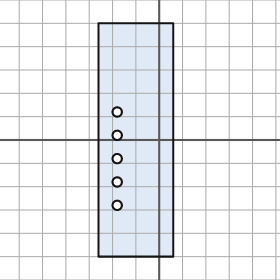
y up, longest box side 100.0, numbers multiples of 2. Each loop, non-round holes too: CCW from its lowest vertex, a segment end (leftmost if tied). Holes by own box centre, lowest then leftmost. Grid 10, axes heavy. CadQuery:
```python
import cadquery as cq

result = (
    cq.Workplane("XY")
    .moveTo(-26.0, -50.0)
    .lineTo(6.0, -50.0)
    .lineTo(6.0, 50.0)
    .lineTo(-26.0, 50.0)
    .close()
    .moveTo(-18.0, -28.0)
    .circle(2.0)
    .moveTo(-18.0, -18.0)
    .circle(2.0)
    .moveTo(-18.0, -8.0)
    .circle(2.0)
    .moveTo(-18.0, 2.0)
    .circle(2.0)
    .moveTo(-18.0, 12.0)
    .circle(2.0)
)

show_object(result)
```